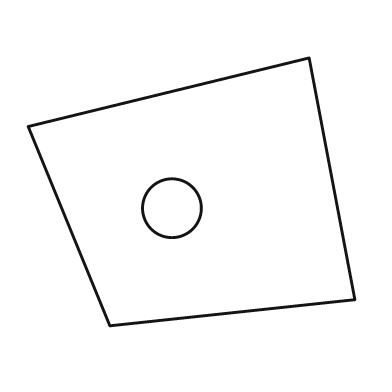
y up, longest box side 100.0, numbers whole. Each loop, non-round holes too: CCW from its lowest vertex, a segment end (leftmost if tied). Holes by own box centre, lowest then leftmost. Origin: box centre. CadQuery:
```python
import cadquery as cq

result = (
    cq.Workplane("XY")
    .moveTo(-25.0, -41.0)
    .lineTo(50.0, -33.0)
    .lineTo(36.0, 41.0)
    .lineTo(-50.0, 20.0)
    .close()
    .moveTo(-6.0, -5.0)
    .circle(9.0)
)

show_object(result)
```